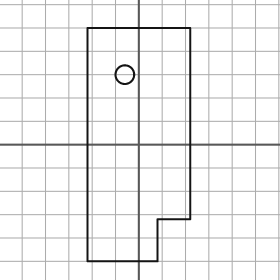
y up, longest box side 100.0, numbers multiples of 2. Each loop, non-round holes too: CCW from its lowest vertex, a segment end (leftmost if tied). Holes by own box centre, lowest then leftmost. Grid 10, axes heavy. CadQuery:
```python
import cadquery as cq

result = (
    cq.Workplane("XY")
    .moveTo(-22.0, -50.0)
    .lineTo(8.0, -50.0)
    .lineTo(8.0, -32.0)
    .lineTo(22.0, -32.0)
    .lineTo(22.0, 50.0)
    .lineTo(-22.0, 50.0)
    .close()
    .moveTo(-6.0, 30.0)
    .circle(4.0)
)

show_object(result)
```